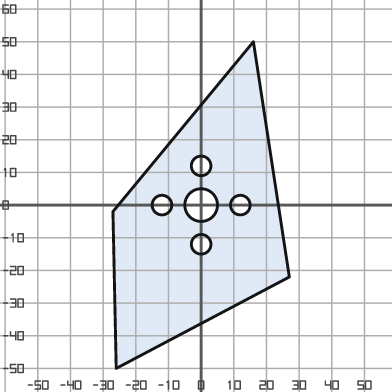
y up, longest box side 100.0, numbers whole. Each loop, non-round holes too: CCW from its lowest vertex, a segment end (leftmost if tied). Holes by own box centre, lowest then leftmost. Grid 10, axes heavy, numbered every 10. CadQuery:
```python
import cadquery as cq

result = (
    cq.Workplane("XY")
    .moveTo(-26.0, -50.0)
    .lineTo(27.0, -22.0)
    .lineTo(16.0, 50.0)
    .lineTo(-27.0, -2.0)
    .close()
    .moveTo(0.0, -12.0)
    .circle(3.0)
    .moveTo(-12.0, 0.0)
    .circle(3.0)
    .moveTo(0.0, 0.0)
    .circle(5.0)
    .moveTo(12.0, 0.0)
    .circle(3.0)
    .moveTo(0.0, 12.0)
    .circle(3.0)
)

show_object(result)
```